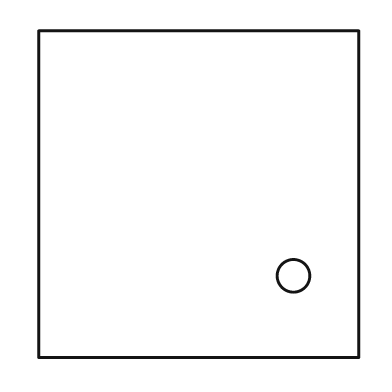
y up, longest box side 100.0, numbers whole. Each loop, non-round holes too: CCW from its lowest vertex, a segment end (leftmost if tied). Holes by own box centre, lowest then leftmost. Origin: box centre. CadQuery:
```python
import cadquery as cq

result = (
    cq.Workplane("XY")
    .moveTo(-49.0, -50.0)
    .lineTo(49.0, -50.0)
    .lineTo(49.0, 50.0)
    .lineTo(-49.0, 50.0)
    .close()
    .moveTo(29.0, -25.0)
    .circle(5.0)
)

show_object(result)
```